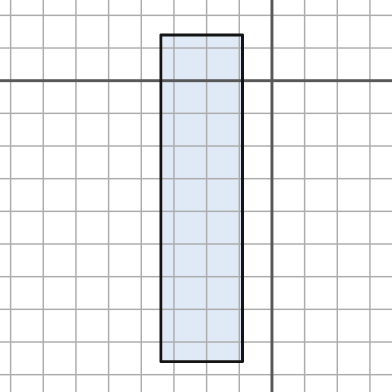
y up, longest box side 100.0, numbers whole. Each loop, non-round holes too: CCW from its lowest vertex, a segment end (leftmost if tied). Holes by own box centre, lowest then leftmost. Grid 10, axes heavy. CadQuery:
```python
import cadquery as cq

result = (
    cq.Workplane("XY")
    .moveTo(-34.0, -86.0)
    .lineTo(-9.0, -86.0)
    .lineTo(-9.0, 14.0)
    .lineTo(-34.0, 14.0)
    .close()
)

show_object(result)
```